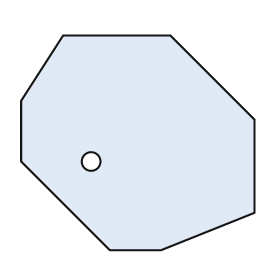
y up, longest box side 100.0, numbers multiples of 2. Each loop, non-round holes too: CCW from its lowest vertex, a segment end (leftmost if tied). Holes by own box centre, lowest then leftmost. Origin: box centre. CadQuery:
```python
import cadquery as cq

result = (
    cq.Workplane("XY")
    .moveTo(-12.0, -46.0)
    .lineTo(10.0, -46.0)
    .lineTo(50.0, -30.0)
    .lineTo(50.0, 10.0)
    .lineTo(14.0, 46.0)
    .lineTo(-32.0, 46.0)
    .lineTo(-50.0, 18.0)
    .lineTo(-50.0, -8.0)
    .close()
    .moveTo(-20.0, -8.0)
    .circle(4.0)
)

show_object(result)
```